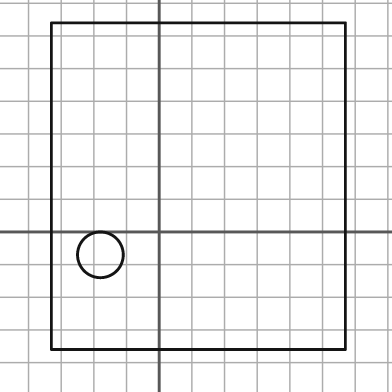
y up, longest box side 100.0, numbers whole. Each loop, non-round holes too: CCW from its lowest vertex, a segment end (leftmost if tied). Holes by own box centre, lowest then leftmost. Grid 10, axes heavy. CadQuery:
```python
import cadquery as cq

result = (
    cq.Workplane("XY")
    .moveTo(-33.0, -36.0)
    .lineTo(57.0, -36.0)
    .lineTo(57.0, 64.0)
    .lineTo(-33.0, 64.0)
    .close()
    .moveTo(-18.0, -7.0)
    .circle(7.0)
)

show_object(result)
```